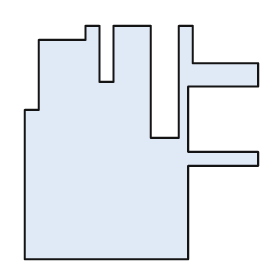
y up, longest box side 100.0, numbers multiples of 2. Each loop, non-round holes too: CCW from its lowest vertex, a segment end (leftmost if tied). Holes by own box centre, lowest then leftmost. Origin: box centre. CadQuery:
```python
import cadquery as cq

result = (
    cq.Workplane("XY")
    .moveTo(-50.0, -50.0)
    .lineTo(20.0, -50.0)
    .lineTo(20.0, -10.0)
    .lineTo(50.0, -10.0)
    .lineTo(50.0, -4.0)
    .lineTo(20.0, -4.0)
    .lineTo(20.0, 24.0)
    .lineTo(50.0, 24.0)
    .lineTo(50.0, 34.0)
    .lineTo(22.0, 34.0)
    .lineTo(22.0, 50.0)
    .lineTo(16.0, 50.0)
    .lineTo(16.0, 2.0)
    .lineTo(4.0, 2.0)
    .lineTo(4.0, 50.0)
    .lineTo(-12.0, 50.0)
    .lineTo(-12.0, 26.0)
    .lineTo(-18.0, 26.0)
    .lineTo(-18.0, 50.0)
    .lineTo(-24.0, 50.0)
    .lineTo(-24.0, 44.0)
    .lineTo(-44.0, 44.0)
    .lineTo(-44.0, 14.0)
    .lineTo(-50.0, 14.0)
    .close()
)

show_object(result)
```